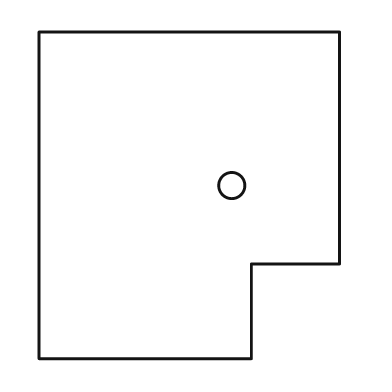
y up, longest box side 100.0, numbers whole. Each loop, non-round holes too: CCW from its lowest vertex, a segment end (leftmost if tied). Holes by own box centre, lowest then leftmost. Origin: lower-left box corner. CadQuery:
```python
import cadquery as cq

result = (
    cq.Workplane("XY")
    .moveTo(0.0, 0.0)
    .lineTo(65.0, 0.0)
    .lineTo(65.0, 29.0)
    .lineTo(92.0, 29.0)
    .lineTo(92.0, 100.0)
    .lineTo(0.0, 100.0)
    .close()
    .moveTo(59.0, 53.0)
    .circle(4.0)
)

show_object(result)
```